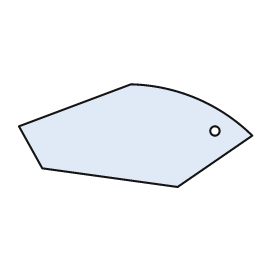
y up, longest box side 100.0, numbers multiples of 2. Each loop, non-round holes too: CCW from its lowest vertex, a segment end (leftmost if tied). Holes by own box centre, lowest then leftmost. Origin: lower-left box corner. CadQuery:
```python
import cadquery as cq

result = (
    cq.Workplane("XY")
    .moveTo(68.0, 0.0)
    .lineTo(100.0, 22.0)
    .threePointArc((76.0, 38.0), (48.0, 44.0))
    .lineTo(0.0, 26.0)
    .lineTo(10.0, 8.0)
    .close()
    .moveTo(84.0, 24.0)
    .circle(2.0)
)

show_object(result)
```